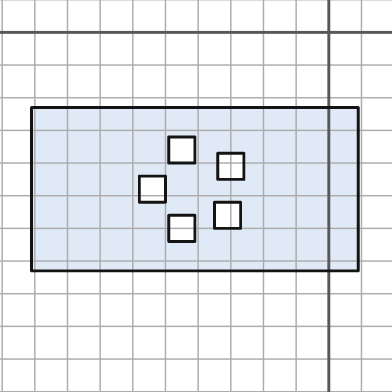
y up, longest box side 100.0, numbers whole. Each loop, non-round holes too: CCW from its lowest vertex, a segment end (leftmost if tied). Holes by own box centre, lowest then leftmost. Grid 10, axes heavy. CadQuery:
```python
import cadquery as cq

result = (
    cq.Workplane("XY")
    .moveTo(-91.0, -73.0)
    .lineTo(9.0, -73.0)
    .lineTo(9.0, -23.0)
    .lineTo(-91.0, -23.0)
    .close()
    .moveTo(-49.0, -64.0)
    .lineTo(-41.0, -64.0)
    .lineTo(-41.0, -56.0)
    .lineTo(-49.0, -56.0)
    .close()
    .moveTo(-35.0, -60.0)
    .lineTo(-27.0, -60.0)
    .lineTo(-27.0, -52.0)
    .lineTo(-35.0, -52.0)
    .close()
    .moveTo(-58.0, -52.0)
    .lineTo(-50.0, -52.0)
    .lineTo(-50.0, -44.0)
    .lineTo(-58.0, -44.0)
    .close()
    .moveTo(-34.0, -45.0)
    .lineTo(-26.0, -45.0)
    .lineTo(-26.0, -37.0)
    .lineTo(-34.0, -37.0)
    .close()
    .moveTo(-49.0, -40.0)
    .lineTo(-41.0, -40.0)
    .lineTo(-41.0, -32.0)
    .lineTo(-49.0, -32.0)
    .close()
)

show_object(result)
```